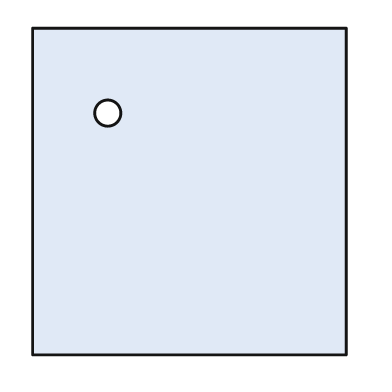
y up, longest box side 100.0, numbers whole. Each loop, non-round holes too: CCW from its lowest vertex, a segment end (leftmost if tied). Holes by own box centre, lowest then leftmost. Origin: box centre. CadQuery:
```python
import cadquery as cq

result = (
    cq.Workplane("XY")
    .moveTo(-48.0, -50.0)
    .lineTo(48.0, -50.0)
    .lineTo(48.0, 50.0)
    .lineTo(-48.0, 50.0)
    .close()
    .moveTo(-25.0, 24.0)
    .circle(4.0)
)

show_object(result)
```